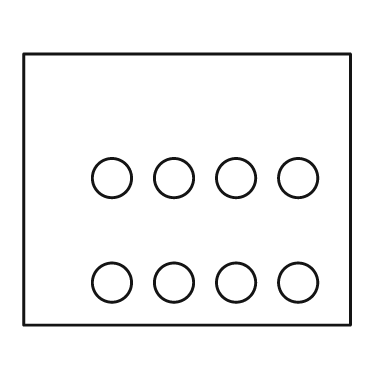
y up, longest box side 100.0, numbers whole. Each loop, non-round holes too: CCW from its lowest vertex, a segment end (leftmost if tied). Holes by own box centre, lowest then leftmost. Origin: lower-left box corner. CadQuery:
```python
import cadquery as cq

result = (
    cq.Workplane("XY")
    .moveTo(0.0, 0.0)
    .lineTo(100.0, 0.0)
    .lineTo(100.0, 83.0)
    .lineTo(0.0, 83.0)
    .close()
    .moveTo(27.0, 13.0)
    .circle(6.0)
    .moveTo(46.0, 13.0)
    .circle(6.0)
    .moveTo(65.0, 13.0)
    .circle(6.0)
    .moveTo(84.0, 13.0)
    .circle(6.0)
    .moveTo(27.0, 45.0)
    .circle(6.0)
    .moveTo(46.0, 45.0)
    .circle(6.0)
    .moveTo(65.0, 45.0)
    .circle(6.0)
    .moveTo(84.0, 45.0)
    .circle(6.0)
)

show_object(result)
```